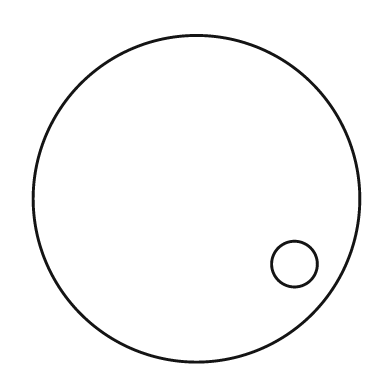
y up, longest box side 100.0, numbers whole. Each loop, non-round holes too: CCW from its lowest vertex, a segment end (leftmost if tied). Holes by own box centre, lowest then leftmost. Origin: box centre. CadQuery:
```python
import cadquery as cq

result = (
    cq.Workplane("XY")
    .moveTo(0.0, 0.0)
    .circle(50.0)
    .moveTo(30.0, -20.0)
    .circle(7.0)
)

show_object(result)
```